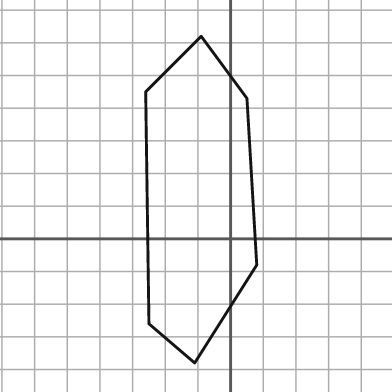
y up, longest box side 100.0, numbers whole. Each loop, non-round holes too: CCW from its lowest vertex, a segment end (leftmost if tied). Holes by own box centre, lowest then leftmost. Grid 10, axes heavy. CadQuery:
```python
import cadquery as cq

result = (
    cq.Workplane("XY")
    .moveTo(-11.0, -38.0)
    .lineTo(8.0, -8.0)
    .lineTo(5.0, 43.0)
    .lineTo(-9.0, 62.0)
    .lineTo(-26.0, 45.0)
    .lineTo(-25.0, -26.0)
    .close()
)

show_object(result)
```